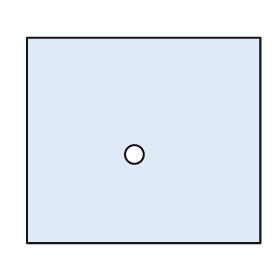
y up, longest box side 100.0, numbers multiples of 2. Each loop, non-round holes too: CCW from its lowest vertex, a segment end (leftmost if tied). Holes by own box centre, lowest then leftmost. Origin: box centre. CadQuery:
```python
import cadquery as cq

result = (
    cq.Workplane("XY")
    .moveTo(-50.0, -44.0)
    .lineTo(50.0, -44.0)
    .lineTo(50.0, 44.0)
    .lineTo(-50.0, 44.0)
    .close()
    .moveTo(-4.0, -6.0)
    .circle(4.0)
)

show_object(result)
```